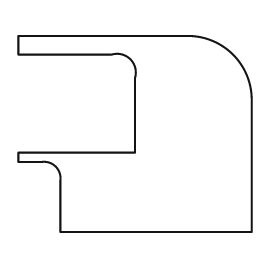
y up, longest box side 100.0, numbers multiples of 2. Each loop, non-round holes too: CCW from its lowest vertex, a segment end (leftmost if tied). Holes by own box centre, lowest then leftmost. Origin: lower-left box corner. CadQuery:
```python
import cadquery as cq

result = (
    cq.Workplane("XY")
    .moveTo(18.0, 0.0)
    .lineTo(100.0, 0.0)
    .lineTo(100.0, 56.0)
    .threePointArc((92.0, 76.0), (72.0, 84.0))
    .lineTo(0.0, 84.0)
    .lineTo(0.0, 76.0)
    .lineTo(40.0, 76.0)
    .threePointArc((48.0, 74.0), (50.0, 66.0))
    .lineTo(50.0, 34.0)
    .lineTo(0.0, 34.0)
    .lineTo(0.0, 30.0)
    .lineTo(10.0, 30.0)
    .threePointArc((16.0, 28.0), (18.0, 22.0))
    .close()
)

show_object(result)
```